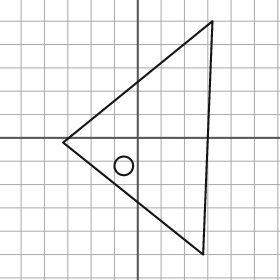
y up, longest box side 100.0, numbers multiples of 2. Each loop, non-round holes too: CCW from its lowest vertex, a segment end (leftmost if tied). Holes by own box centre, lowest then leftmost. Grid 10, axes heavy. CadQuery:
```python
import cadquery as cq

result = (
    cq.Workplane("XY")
    .moveTo(28.0, -50.0)
    .lineTo(32.0, 50.0)
    .lineTo(-32.0, -2.0)
    .close()
    .moveTo(-6.0, -12.0)
    .circle(4.0)
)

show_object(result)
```